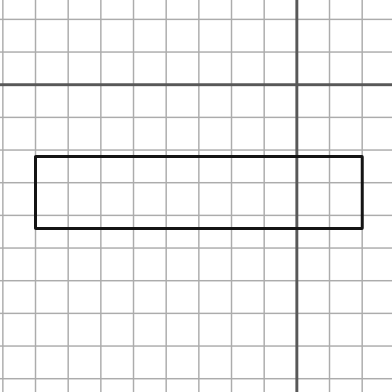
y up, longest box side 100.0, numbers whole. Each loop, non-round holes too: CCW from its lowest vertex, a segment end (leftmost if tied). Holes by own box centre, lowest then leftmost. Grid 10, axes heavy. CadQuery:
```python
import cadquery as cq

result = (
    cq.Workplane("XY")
    .moveTo(-80.0, -44.0)
    .lineTo(20.0, -44.0)
    .lineTo(20.0, -22.0)
    .lineTo(-80.0, -22.0)
    .close()
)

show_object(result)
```